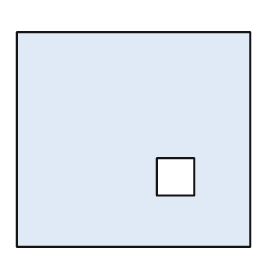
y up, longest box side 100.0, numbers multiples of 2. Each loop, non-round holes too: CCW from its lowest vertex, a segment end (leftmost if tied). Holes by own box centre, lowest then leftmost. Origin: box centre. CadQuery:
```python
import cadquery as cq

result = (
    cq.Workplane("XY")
    .moveTo(-50.0, -46.0)
    .lineTo(50.0, -46.0)
    .lineTo(50.0, 46.0)
    .lineTo(-50.0, 46.0)
    .close()
    .moveTo(10.0, -24.0)
    .lineTo(26.0, -24.0)
    .lineTo(26.0, -8.0)
    .lineTo(10.0, -8.0)
    .close()
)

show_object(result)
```